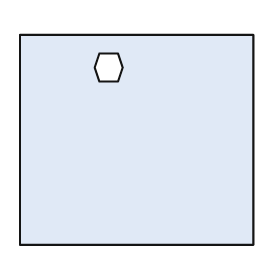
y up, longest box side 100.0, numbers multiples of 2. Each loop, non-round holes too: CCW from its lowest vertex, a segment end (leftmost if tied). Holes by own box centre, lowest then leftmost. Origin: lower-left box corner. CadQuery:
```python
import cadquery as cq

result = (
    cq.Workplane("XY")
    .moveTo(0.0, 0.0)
    .lineTo(100.0, 0.0)
    .lineTo(100.0, 90.0)
    .lineTo(0.0, 90.0)
    .close()
    .moveTo(34.0, 70.0)
    .lineTo(42.0, 70.0)
    .lineTo(44.0, 76.0)
    .lineTo(42.0, 82.0)
    .lineTo(34.0, 82.0)
    .lineTo(32.0, 76.0)
    .close()
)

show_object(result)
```